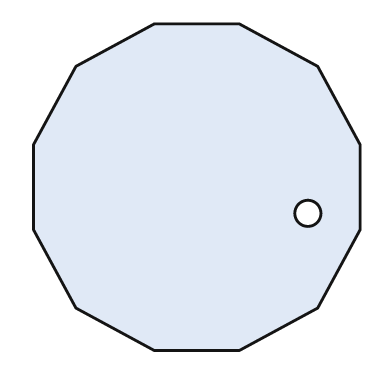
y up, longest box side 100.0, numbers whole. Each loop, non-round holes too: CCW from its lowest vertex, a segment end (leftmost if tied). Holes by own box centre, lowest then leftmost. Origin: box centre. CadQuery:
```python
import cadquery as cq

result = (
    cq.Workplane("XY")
    .moveTo(-13.0, -50.0)
    .lineTo(13.0, -50.0)
    .lineTo(37.0, -37.0)
    .lineTo(50.0, -13.0)
    .lineTo(50.0, 13.0)
    .lineTo(37.0, 37.0)
    .lineTo(13.0, 50.0)
    .lineTo(-13.0, 50.0)
    .lineTo(-37.0, 37.0)
    .lineTo(-50.0, 13.0)
    .lineTo(-50.0, -13.0)
    .lineTo(-37.0, -37.0)
    .close()
    .moveTo(34.0, -8.0)
    .circle(4.0)
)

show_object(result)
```